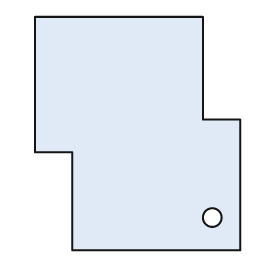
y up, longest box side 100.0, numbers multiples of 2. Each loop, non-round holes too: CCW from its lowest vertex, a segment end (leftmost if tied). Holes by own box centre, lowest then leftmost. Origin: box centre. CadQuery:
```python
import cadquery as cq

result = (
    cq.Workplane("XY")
    .moveTo(-28.0, -50.0)
    .lineTo(44.0, -50.0)
    .lineTo(44.0, 6.0)
    .lineTo(28.0, 6.0)
    .lineTo(28.0, 50.0)
    .lineTo(-44.0, 50.0)
    .lineTo(-44.0, -8.0)
    .lineTo(-28.0, -8.0)
    .close()
    .moveTo(32.0, -36.0)
    .circle(4.0)
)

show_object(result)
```